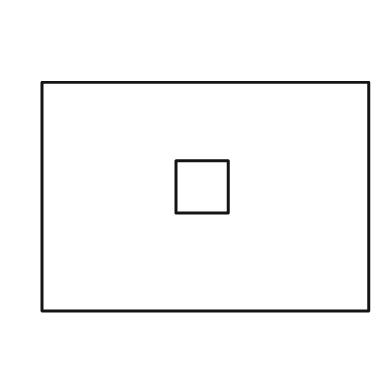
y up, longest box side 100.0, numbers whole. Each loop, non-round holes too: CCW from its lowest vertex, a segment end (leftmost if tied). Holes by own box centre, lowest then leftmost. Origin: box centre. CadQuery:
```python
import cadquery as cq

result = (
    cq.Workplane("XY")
    .moveTo(-50.0, -35.0)
    .lineTo(50.0, -35.0)
    .lineTo(50.0, 35.0)
    .lineTo(-50.0, 35.0)
    .close()
    .moveTo(-9.0, -5.0)
    .lineTo(7.0, -5.0)
    .lineTo(7.0, 11.0)
    .lineTo(-9.0, 11.0)
    .close()
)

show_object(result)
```